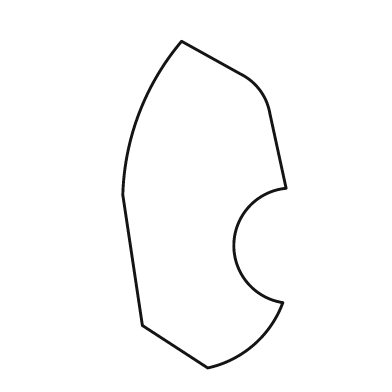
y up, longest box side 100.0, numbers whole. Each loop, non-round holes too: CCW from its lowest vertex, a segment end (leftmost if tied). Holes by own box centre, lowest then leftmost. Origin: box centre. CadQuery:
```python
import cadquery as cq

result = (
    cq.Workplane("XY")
    .moveTo(1.0, -50.0)
    .threePointArc((15.0, -43.0), (24.0, -30.0))
    .threePointArc((9.0, -12.0), (25.0, 5.0))
    .lineTo(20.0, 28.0)
    .threePointArc((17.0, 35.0), (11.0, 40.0))
    .lineTo(-7.0, 50.0)
    .threePointArc((-20.0, 28.0), (-25.0, 3.0))
    .lineTo(-19.0, -37.0)
    .close()
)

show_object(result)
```